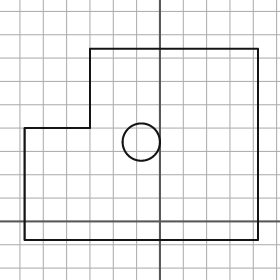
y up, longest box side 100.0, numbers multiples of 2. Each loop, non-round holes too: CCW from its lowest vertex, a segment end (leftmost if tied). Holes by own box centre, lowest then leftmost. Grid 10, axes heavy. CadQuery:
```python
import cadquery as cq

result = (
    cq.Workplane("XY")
    .moveTo(-58.0, -8.0)
    .lineTo(42.0, -8.0)
    .lineTo(42.0, 74.0)
    .lineTo(-30.0, 74.0)
    .lineTo(-30.0, 40.0)
    .lineTo(-58.0, 40.0)
    .close()
    .moveTo(-8.0, 34.0)
    .circle(8.0)
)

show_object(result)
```